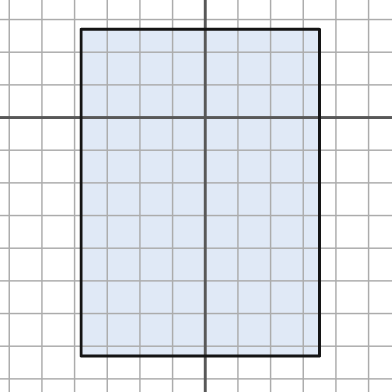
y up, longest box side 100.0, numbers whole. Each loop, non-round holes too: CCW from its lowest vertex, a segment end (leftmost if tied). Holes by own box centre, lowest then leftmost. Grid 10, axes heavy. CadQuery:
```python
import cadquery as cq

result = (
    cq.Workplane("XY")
    .moveTo(-38.0, -73.0)
    .lineTo(35.0, -73.0)
    .lineTo(35.0, 27.0)
    .lineTo(-38.0, 27.0)
    .close()
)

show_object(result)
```